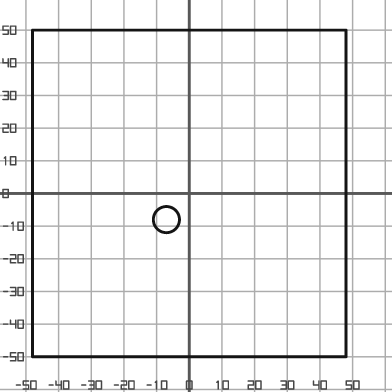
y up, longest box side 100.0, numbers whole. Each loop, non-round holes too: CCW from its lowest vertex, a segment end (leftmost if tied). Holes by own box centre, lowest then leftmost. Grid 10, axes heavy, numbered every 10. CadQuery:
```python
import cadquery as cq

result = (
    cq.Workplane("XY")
    .moveTo(-48.0, -50.0)
    .lineTo(48.0, -50.0)
    .lineTo(48.0, 50.0)
    .lineTo(-48.0, 50.0)
    .close()
    .moveTo(-7.0, -8.0)
    .circle(4.0)
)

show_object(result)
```